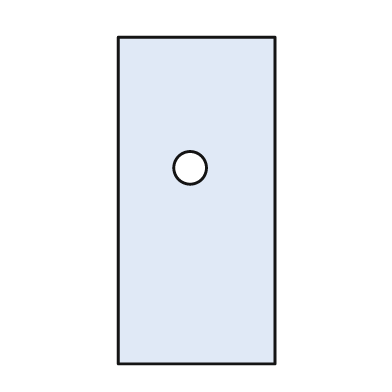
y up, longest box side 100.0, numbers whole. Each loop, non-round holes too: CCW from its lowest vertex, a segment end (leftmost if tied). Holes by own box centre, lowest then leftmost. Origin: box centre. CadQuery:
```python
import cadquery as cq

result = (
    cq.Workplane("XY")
    .moveTo(-24.0, -50.0)
    .lineTo(24.0, -50.0)
    .lineTo(24.0, 50.0)
    .lineTo(-24.0, 50.0)
    .close()
    .moveTo(-2.0, 10.0)
    .circle(5.0)
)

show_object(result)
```